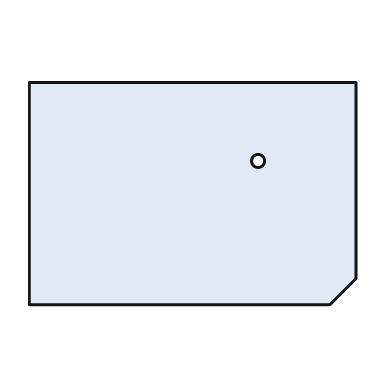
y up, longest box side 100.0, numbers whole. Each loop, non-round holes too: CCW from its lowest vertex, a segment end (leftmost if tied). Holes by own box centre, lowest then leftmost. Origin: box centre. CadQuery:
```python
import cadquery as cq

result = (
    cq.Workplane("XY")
    .moveTo(-50.0, -34.0)
    .lineTo(42.0, -34.0)
    .lineTo(50.0, -26.0)
    .lineTo(50.0, 34.0)
    .lineTo(-50.0, 34.0)
    .close()
    .moveTo(20.0, 10.0)
    .circle(2.0)
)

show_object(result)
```